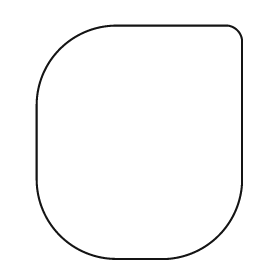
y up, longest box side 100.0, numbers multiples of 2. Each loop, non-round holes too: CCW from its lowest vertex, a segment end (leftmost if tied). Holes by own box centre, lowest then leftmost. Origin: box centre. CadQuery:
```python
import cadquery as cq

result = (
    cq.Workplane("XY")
    .moveTo(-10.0, -50.0)
    .lineTo(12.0, -50.0)
    .threePointArc((34.0, -40.0), (44.0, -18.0))
    .lineTo(44.0, 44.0)
    .threePointArc((42.0, 48.0), (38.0, 50.0))
    .lineTo(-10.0, 50.0)
    .threePointArc((-34.0, 40.0), (-44.0, 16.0))
    .lineTo(-44.0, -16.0)
    .threePointArc((-34.0, -40.0), (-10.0, -50.0))
    .close()
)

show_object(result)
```